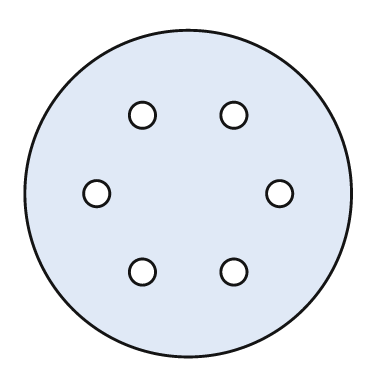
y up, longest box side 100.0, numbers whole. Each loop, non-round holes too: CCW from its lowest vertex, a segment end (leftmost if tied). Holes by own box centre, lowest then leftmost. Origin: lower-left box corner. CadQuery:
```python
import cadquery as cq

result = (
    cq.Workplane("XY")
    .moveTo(50.0, 50.0)
    .circle(50.0)
    .moveTo(36.0, 26.0)
    .circle(4.0)
    .moveTo(64.0, 26.0)
    .circle(4.0)
    .moveTo(22.0, 50.0)
    .circle(4.0)
    .moveTo(78.0, 50.0)
    .circle(4.0)
    .moveTo(36.0, 74.0)
    .circle(4.0)
    .moveTo(64.0, 74.0)
    .circle(4.0)
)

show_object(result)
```